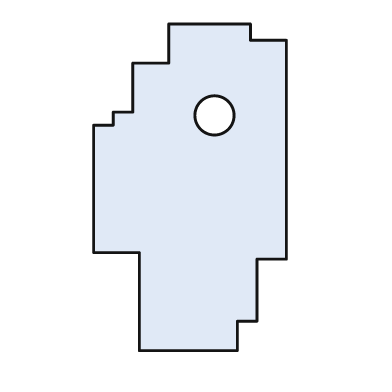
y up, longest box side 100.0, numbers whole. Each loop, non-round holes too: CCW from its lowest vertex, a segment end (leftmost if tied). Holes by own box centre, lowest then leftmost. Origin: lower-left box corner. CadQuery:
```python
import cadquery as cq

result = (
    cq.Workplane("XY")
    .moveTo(14.0, 0.0)
    .lineTo(44.0, 0.0)
    .lineTo(44.0, 9.0)
    .lineTo(50.0, 9.0)
    .lineTo(50.0, 28.0)
    .lineTo(59.0, 28.0)
    .lineTo(59.0, 95.0)
    .lineTo(48.0, 95.0)
    .lineTo(48.0, 100.0)
    .lineTo(23.0, 100.0)
    .lineTo(23.0, 88.0)
    .lineTo(12.0, 88.0)
    .lineTo(12.0, 73.0)
    .lineTo(6.0, 73.0)
    .lineTo(6.0, 69.0)
    .lineTo(0.0, 69.0)
    .lineTo(0.0, 30.0)
    .lineTo(14.0, 30.0)
    .close()
    .moveTo(37.0, 72.0)
    .circle(6.0)
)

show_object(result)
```